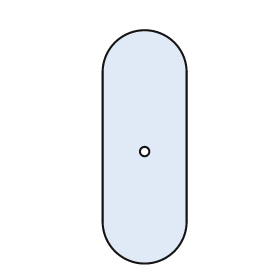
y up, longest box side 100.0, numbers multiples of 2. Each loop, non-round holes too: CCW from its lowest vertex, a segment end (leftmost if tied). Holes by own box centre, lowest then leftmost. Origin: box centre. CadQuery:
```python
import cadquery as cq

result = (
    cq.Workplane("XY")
    .moveTo(-18.0, -32.0)
    .threePointArc((0.0, -50.0), (18.0, -32.0))
    .lineTo(18.0, 32.0)
    .threePointArc((0.0, 50.0), (-18.0, 32.0))
    .close()
    .moveTo(0.0, -2.0)
    .circle(2.0)
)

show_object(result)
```